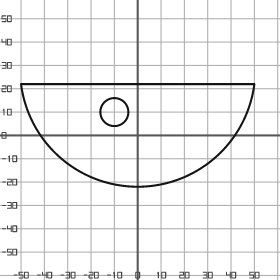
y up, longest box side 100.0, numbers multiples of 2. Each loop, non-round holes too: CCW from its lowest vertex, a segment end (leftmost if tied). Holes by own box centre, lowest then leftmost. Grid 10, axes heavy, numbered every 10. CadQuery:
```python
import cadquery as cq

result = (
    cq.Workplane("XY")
    .moveTo(-50.0, 22.0)
    .threePointArc((0.0, -22.0), (50.0, 22.0))
    .close()
    .moveTo(-10.0, 10.0)
    .circle(6.0)
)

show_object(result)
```